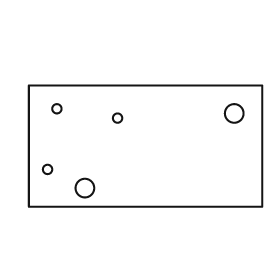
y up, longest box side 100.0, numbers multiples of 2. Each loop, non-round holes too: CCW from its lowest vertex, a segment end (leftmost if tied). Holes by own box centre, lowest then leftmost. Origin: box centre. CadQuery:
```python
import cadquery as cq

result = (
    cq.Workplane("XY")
    .moveTo(-50.0, -26.0)
    .lineTo(50.0, -26.0)
    .lineTo(50.0, 26.0)
    .lineTo(-50.0, 26.0)
    .close()
    .moveTo(-26.0, -18.0)
    .circle(4.0)
    .moveTo(-42.0, -10.0)
    .circle(2.0)
    .moveTo(-12.0, 12.0)
    .circle(2.0)
    .moveTo(38.0, 14.0)
    .circle(4.0)
    .moveTo(-38.0, 16.0)
    .circle(2.0)
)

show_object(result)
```